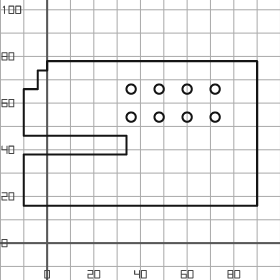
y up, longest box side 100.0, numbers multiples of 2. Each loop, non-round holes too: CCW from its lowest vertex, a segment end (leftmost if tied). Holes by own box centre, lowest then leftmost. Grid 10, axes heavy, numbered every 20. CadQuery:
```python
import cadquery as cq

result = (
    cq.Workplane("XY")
    .moveTo(-10.0, 16.0)
    .lineTo(90.0, 16.0)
    .lineTo(90.0, 78.0)
    .lineTo(0.0, 78.0)
    .lineTo(0.0, 74.0)
    .lineTo(-4.0, 74.0)
    .lineTo(-4.0, 66.0)
    .lineTo(-10.0, 66.0)
    .lineTo(-10.0, 46.0)
    .lineTo(34.0, 46.0)
    .lineTo(34.0, 38.0)
    .lineTo(-10.0, 38.0)
    .close()
    .moveTo(36.0, 54.0)
    .circle(2.0)
    .moveTo(48.0, 54.0)
    .circle(2.0)
    .moveTo(60.0, 54.0)
    .circle(2.0)
    .moveTo(72.0, 54.0)
    .circle(2.0)
    .moveTo(36.0, 66.0)
    .circle(2.0)
    .moveTo(48.0, 66.0)
    .circle(2.0)
    .moveTo(60.0, 66.0)
    .circle(2.0)
    .moveTo(72.0, 66.0)
    .circle(2.0)
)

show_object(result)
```